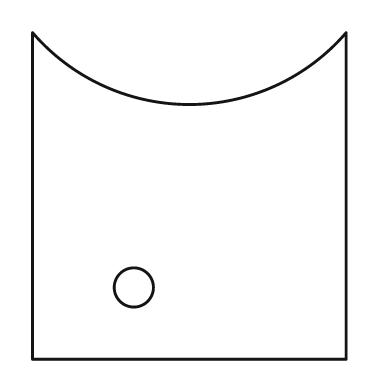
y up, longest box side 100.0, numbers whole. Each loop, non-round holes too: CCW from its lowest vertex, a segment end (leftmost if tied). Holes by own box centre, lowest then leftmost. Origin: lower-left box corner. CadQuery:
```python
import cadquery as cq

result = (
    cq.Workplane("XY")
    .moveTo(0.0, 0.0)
    .lineTo(96.0, 0.0)
    .lineTo(96.0, 100.0)
    .threePointArc((48.0, 78.0), (0.0, 100.0))
    .close()
    .moveTo(31.0, 22.0)
    .circle(6.0)
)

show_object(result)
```